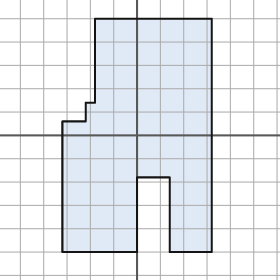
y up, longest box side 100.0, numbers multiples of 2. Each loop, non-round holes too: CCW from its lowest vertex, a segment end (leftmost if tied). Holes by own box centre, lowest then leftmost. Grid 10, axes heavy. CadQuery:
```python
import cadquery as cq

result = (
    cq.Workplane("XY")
    .moveTo(-32.0, -50.0)
    .lineTo(0.0, -50.0)
    .lineTo(0.0, -18.0)
    .lineTo(14.0, -18.0)
    .lineTo(14.0, -50.0)
    .lineTo(32.0, -50.0)
    .lineTo(32.0, 50.0)
    .lineTo(-18.0, 50.0)
    .lineTo(-18.0, 14.0)
    .lineTo(-22.0, 14.0)
    .lineTo(-22.0, 6.0)
    .lineTo(-32.0, 6.0)
    .close()
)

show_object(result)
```